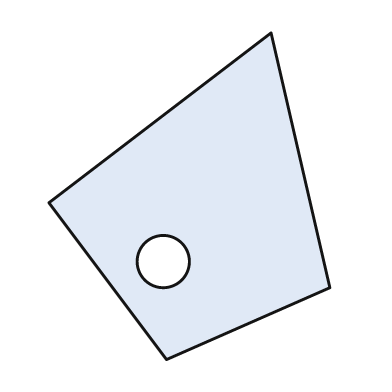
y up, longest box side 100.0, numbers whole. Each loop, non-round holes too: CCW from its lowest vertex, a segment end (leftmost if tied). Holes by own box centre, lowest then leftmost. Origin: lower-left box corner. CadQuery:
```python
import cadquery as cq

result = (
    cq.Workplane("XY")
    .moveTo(36.0, 0.0)
    .lineTo(86.0, 22.0)
    .lineTo(68.0, 100.0)
    .lineTo(0.0, 48.0)
    .close()
    .moveTo(35.0, 30.0)
    .circle(8.0)
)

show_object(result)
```